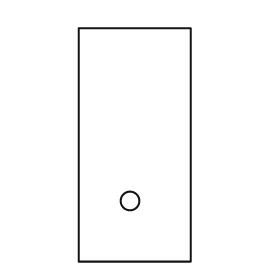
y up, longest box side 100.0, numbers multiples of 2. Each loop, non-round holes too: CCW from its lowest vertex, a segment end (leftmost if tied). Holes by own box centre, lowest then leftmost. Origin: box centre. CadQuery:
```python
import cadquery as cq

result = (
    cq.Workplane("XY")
    .moveTo(-24.0, -50.0)
    .lineTo(24.0, -50.0)
    .lineTo(24.0, 50.0)
    .lineTo(-24.0, 50.0)
    .close()
    .moveTo(-2.0, -24.0)
    .circle(4.0)
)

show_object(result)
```